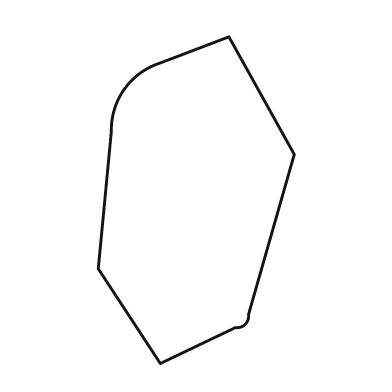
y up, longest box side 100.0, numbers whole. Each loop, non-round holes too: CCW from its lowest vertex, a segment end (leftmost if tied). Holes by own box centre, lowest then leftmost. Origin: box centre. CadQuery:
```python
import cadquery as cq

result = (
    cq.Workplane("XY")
    .moveTo(-11.0, -50.0)
    .lineTo(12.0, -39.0)
    .threePointArc((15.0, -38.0), (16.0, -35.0))
    .lineTo(30.0, 14.0)
    .lineTo(10.0, 50.0)
    .lineTo(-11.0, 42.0)
    .threePointArc((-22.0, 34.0), (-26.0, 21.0))
    .lineTo(-30.0, -21.0)
    .close()
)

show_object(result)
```